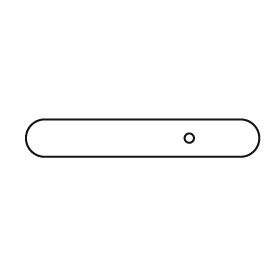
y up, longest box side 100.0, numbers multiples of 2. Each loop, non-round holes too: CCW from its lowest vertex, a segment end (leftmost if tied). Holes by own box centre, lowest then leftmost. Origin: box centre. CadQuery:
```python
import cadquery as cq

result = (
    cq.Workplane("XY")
    .moveTo(-42.0, -8.0)
    .lineTo(42.0, -8.0)
    .threePointArc((50.0, 0.0), (42.0, 8.0))
    .lineTo(-42.0, 8.0)
    .threePointArc((-50.0, 0.0), (-42.0, -8.0))
    .close()
    .moveTo(20.0, 0.0)
    .circle(2.0)
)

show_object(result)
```